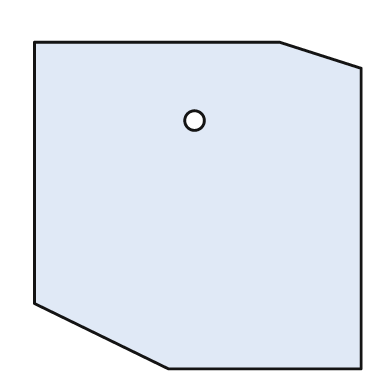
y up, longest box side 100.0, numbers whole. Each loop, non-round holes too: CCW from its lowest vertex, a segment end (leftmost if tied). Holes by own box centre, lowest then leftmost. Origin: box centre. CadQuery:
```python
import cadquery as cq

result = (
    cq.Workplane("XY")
    .moveTo(-9.0, -50.0)
    .lineTo(50.0, -50.0)
    .lineTo(50.0, 42.0)
    .lineTo(25.0, 50.0)
    .lineTo(-50.0, 50.0)
    .lineTo(-50.0, -30.0)
    .close()
    .moveTo(-1.0, 26.0)
    .circle(3.0)
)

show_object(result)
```